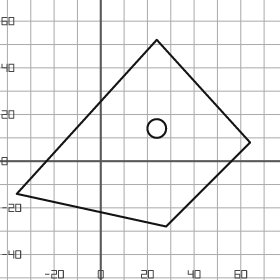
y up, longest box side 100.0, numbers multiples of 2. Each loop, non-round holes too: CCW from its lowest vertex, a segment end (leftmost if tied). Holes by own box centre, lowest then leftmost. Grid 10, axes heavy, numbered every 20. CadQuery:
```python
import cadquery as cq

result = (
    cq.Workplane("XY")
    .moveTo(28.0, -28.0)
    .lineTo(64.0, 8.0)
    .lineTo(24.0, 52.0)
    .lineTo(-36.0, -14.0)
    .close()
    .moveTo(24.0, 14.0)
    .circle(4.0)
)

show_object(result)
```